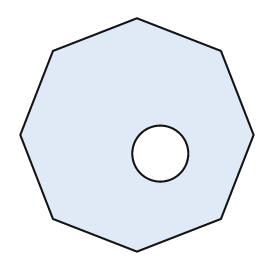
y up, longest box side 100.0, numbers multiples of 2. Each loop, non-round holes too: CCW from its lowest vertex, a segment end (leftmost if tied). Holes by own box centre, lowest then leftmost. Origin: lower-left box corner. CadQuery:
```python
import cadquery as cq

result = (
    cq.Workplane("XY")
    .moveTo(50.0, 0.0)
    .lineTo(86.0, 14.0)
    .lineTo(100.0, 50.0)
    .lineTo(86.0, 86.0)
    .lineTo(50.0, 100.0)
    .lineTo(14.0, 86.0)
    .lineTo(0.0, 50.0)
    .lineTo(14.0, 14.0)
    .close()
    .moveTo(60.0, 42.0)
    .circle(12.0)
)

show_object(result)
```